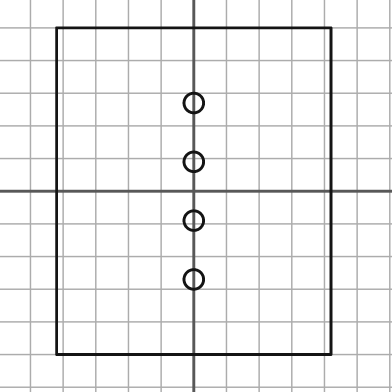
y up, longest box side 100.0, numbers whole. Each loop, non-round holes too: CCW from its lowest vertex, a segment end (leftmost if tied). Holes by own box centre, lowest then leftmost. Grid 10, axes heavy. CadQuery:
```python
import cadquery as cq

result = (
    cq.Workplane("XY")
    .moveTo(-42.0, -50.0)
    .lineTo(42.0, -50.0)
    .lineTo(42.0, 50.0)
    .lineTo(-42.0, 50.0)
    .close()
    .moveTo(0.0, -27.0)
    .circle(3.0)
    .moveTo(0.0, -9.0)
    .circle(3.0)
    .moveTo(0.0, 9.0)
    .circle(3.0)
    .moveTo(0.0, 27.0)
    .circle(3.0)
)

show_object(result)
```